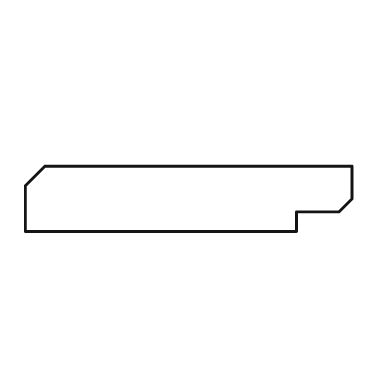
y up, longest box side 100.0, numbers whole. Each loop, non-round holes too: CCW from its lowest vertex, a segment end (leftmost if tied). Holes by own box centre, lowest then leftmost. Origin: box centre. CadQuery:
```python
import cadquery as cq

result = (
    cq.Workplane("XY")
    .moveTo(-50.0, -10.0)
    .lineTo(33.0, -10.0)
    .lineTo(33.0, -4.0)
    .lineTo(46.0, -4.0)
    .lineTo(50.0, 0.0)
    .lineTo(50.0, 10.0)
    .lineTo(-44.0, 10.0)
    .lineTo(-50.0, 4.0)
    .close()
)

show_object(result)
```